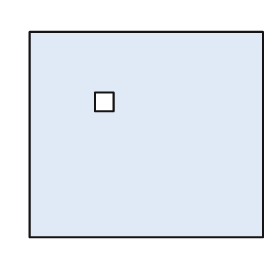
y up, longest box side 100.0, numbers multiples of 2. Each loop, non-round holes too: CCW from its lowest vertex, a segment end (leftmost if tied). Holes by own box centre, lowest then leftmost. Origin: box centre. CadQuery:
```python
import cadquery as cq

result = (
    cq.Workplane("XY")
    .moveTo(-50.0, -44.0)
    .lineTo(50.0, -44.0)
    .lineTo(50.0, 44.0)
    .lineTo(-50.0, 44.0)
    .close()
    .moveTo(-22.0, 10.0)
    .lineTo(-14.0, 10.0)
    .lineTo(-14.0, 18.0)
    .lineTo(-22.0, 18.0)
    .close()
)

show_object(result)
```